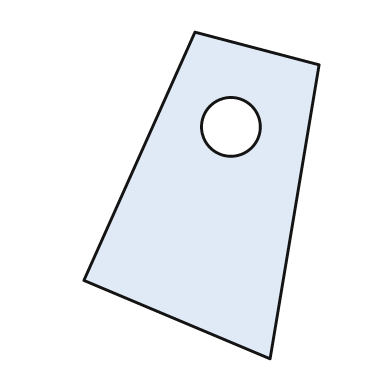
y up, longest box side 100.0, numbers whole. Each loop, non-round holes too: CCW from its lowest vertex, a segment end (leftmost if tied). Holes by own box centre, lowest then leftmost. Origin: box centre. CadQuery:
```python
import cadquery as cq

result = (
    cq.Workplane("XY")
    .moveTo(21.0, -50.0)
    .lineTo(36.0, 40.0)
    .lineTo(-2.0, 50.0)
    .lineTo(-36.0, -26.0)
    .close()
    .moveTo(9.0, 21.0)
    .circle(9.0)
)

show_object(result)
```